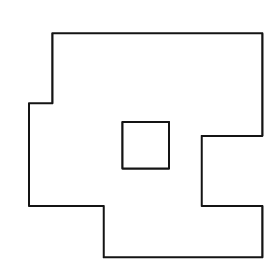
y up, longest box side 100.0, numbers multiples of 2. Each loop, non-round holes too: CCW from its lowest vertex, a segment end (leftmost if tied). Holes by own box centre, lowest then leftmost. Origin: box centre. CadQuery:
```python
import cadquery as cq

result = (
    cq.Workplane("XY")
    .moveTo(-18.0, -48.0)
    .lineTo(50.0, -48.0)
    .lineTo(50.0, -26.0)
    .lineTo(24.0, -26.0)
    .lineTo(24.0, 4.0)
    .lineTo(50.0, 4.0)
    .lineTo(50.0, 48.0)
    .lineTo(-40.0, 48.0)
    .lineTo(-40.0, 18.0)
    .lineTo(-50.0, 18.0)
    .lineTo(-50.0, -26.0)
    .lineTo(-18.0, -26.0)
    .close()
    .moveTo(-10.0, -10.0)
    .lineTo(10.0, -10.0)
    .lineTo(10.0, 10.0)
    .lineTo(-10.0, 10.0)
    .close()
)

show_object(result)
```